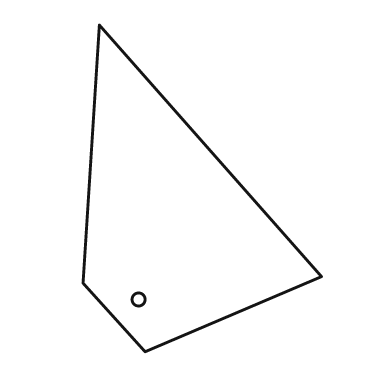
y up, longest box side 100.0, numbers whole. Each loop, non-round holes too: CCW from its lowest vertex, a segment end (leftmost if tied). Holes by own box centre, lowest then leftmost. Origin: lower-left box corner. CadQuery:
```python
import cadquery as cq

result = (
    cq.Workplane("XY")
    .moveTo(19.0, 0.0)
    .lineTo(73.0, 23.0)
    .lineTo(5.0, 100.0)
    .lineTo(0.0, 21.0)
    .close()
    .moveTo(17.0, 16.0)
    .circle(2.0)
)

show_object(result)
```